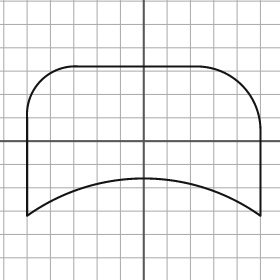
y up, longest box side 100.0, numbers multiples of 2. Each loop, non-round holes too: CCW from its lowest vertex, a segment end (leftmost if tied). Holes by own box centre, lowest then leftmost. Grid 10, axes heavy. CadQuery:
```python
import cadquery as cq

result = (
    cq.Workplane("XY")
    .moveTo(-50.0, -32.0)
    .threePointArc((0.0, -16.0), (50.0, -32.0))
    .lineTo(50.0, 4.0)
    .threePointArc((42.0, 24.0), (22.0, 32.0))
    .lineTo(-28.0, 32.0)
    .threePointArc((-44.0, 26.0), (-50.0, 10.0))
    .close()
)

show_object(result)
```